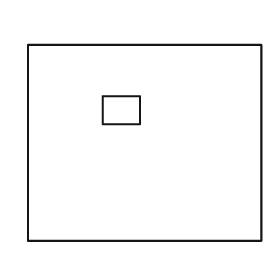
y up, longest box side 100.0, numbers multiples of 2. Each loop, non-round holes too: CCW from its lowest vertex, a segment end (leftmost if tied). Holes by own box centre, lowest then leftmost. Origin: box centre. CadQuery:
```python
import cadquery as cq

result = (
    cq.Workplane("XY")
    .moveTo(-50.0, -42.0)
    .lineTo(50.0, -42.0)
    .lineTo(50.0, 42.0)
    .lineTo(-50.0, 42.0)
    .close()
    .moveTo(-18.0, 8.0)
    .lineTo(-2.0, 8.0)
    .lineTo(-2.0, 20.0)
    .lineTo(-18.0, 20.0)
    .close()
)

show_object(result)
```